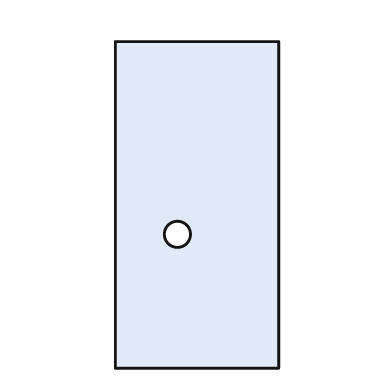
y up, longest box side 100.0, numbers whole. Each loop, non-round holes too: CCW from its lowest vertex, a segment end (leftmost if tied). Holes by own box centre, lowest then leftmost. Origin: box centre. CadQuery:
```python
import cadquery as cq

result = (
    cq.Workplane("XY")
    .moveTo(-25.0, -50.0)
    .lineTo(25.0, -50.0)
    .lineTo(25.0, 50.0)
    .lineTo(-25.0, 50.0)
    .close()
    .moveTo(-6.0, -9.0)
    .circle(4.0)
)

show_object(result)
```